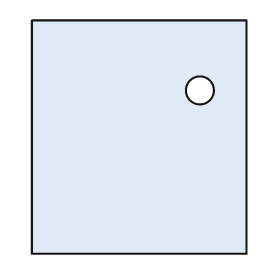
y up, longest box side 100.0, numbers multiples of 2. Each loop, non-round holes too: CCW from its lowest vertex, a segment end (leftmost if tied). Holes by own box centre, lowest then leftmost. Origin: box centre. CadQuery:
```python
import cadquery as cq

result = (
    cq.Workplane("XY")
    .moveTo(-46.0, -50.0)
    .lineTo(46.0, -50.0)
    .lineTo(46.0, 50.0)
    .lineTo(-46.0, 50.0)
    .close()
    .moveTo(26.0, 20.0)
    .circle(6.0)
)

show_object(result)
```